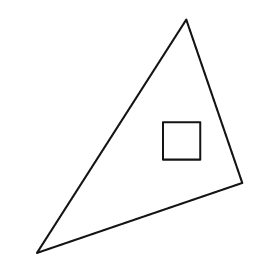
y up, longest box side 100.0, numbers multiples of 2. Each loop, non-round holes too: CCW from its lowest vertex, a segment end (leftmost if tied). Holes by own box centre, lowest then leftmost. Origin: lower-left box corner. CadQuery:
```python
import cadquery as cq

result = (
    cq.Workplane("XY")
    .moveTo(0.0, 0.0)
    .lineTo(88.0, 30.0)
    .lineTo(64.0, 100.0)
    .close()
    .moveTo(54.0, 40.0)
    .lineTo(70.0, 40.0)
    .lineTo(70.0, 56.0)
    .lineTo(54.0, 56.0)
    .close()
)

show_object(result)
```